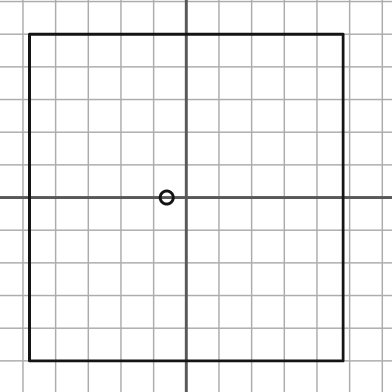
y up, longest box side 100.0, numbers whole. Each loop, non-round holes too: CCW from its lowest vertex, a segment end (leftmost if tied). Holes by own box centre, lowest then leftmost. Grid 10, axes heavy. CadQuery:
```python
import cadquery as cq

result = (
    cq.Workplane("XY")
    .moveTo(-48.0, -50.0)
    .lineTo(48.0, -50.0)
    .lineTo(48.0, 50.0)
    .lineTo(-48.0, 50.0)
    .close()
    .moveTo(-6.0, 0.0)
    .circle(2.0)
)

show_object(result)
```